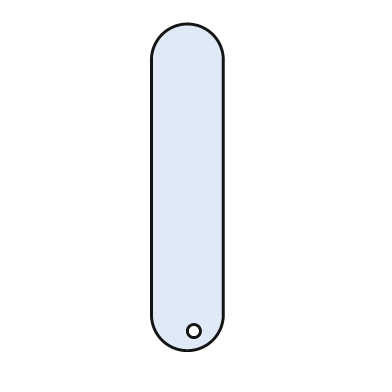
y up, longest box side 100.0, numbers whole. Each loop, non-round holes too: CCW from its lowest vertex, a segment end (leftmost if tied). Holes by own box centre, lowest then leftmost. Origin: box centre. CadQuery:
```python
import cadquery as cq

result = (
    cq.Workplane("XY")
    .moveTo(-11.0, -39.0)
    .threePointArc((0.0, -50.0), (11.0, -39.0))
    .lineTo(11.0, 39.0)
    .threePointArc((0.0, 50.0), (-11.0, 39.0))
    .close()
    .moveTo(2.0, -44.0)
    .circle(2.0)
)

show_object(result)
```